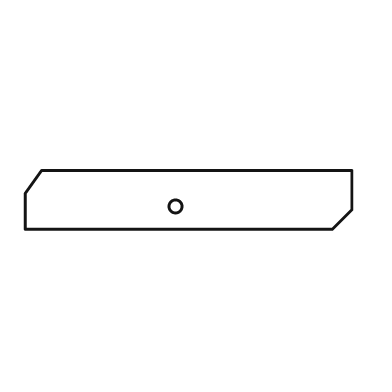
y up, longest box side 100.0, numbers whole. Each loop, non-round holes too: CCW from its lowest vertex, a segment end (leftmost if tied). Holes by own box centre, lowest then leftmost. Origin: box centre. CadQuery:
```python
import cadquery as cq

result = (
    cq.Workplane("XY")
    .moveTo(-50.0, -9.0)
    .lineTo(44.0, -9.0)
    .lineTo(50.0, -3.0)
    .lineTo(50.0, 9.0)
    .lineTo(-45.0, 9.0)
    .lineTo(-50.0, 2.0)
    .close()
    .moveTo(-4.0, -2.0)
    .circle(2.0)
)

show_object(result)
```